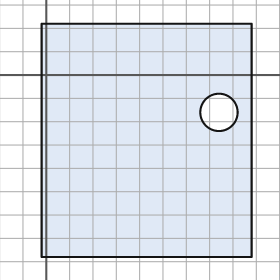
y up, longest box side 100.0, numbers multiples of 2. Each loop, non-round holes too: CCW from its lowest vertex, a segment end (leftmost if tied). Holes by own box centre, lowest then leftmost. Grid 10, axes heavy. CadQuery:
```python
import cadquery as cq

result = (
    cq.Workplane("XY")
    .moveTo(-2.0, -78.0)
    .lineTo(88.0, -78.0)
    .lineTo(88.0, 22.0)
    .lineTo(-2.0, 22.0)
    .close()
    .moveTo(74.0, -16.0)
    .circle(8.0)
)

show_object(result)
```